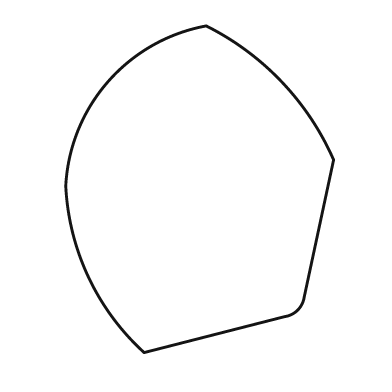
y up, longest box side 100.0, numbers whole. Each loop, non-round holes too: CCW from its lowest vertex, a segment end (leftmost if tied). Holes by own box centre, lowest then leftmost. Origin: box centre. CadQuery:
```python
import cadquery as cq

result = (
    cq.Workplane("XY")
    .moveTo(-17.0, -50.0)
    .lineTo(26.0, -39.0)
    .threePointArc((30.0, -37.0), (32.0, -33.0))
    .lineTo(41.0, 9.0)
    .threePointArc((25.0, 33.0), (2.0, 50.0))
    .threePointArc((-28.0, 33.0), (-41.0, 1.0))
    .threePointArc((-34.0, -27.0), (-17.0, -50.0))
    .close()
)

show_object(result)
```